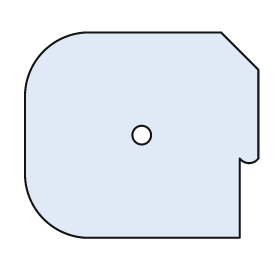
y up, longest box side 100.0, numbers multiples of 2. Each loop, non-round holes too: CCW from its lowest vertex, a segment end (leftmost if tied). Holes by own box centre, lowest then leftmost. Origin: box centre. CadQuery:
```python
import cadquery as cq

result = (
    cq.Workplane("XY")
    .moveTo(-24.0, -44.0)
    .lineTo(42.0, -44.0)
    .lineTo(42.0, -10.0)
    .threePointArc((46.0, -12.0), (50.0, -10.0))
    .lineTo(50.0, 28.0)
    .lineTo(34.0, 44.0)
    .lineTo(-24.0, 44.0)
    .threePointArc((-42.0, 36.0), (-50.0, 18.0))
    .lineTo(-50.0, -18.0)
    .threePointArc((-42.0, -36.0), (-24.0, -44.0))
    .close()
    .moveTo(0.0, 0.0)
    .circle(4.0)
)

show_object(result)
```